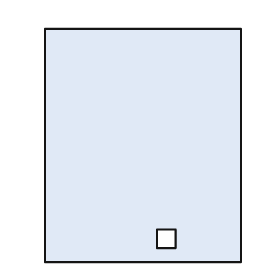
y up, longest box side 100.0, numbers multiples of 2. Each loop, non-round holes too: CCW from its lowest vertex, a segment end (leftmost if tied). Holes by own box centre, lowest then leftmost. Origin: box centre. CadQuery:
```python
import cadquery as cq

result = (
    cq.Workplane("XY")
    .moveTo(-42.0, -50.0)
    .lineTo(42.0, -50.0)
    .lineTo(42.0, 50.0)
    .lineTo(-42.0, 50.0)
    .close()
    .moveTo(6.0, -44.0)
    .lineTo(14.0, -44.0)
    .lineTo(14.0, -36.0)
    .lineTo(6.0, -36.0)
    .close()
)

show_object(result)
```